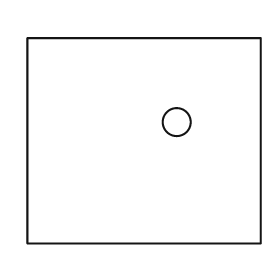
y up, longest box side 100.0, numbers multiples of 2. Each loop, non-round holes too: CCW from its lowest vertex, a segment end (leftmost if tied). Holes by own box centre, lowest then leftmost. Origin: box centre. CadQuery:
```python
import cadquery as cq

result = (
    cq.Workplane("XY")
    .moveTo(-50.0, -44.0)
    .lineTo(50.0, -44.0)
    .lineTo(50.0, 44.0)
    .lineTo(-50.0, 44.0)
    .close()
    .moveTo(14.0, 8.0)
    .circle(6.0)
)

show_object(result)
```